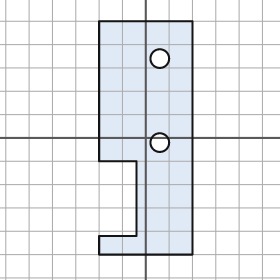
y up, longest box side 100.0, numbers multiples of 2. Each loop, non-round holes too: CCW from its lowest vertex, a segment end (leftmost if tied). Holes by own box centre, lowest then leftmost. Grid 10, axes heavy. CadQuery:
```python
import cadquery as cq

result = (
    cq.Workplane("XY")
    .moveTo(-20.0, -50.0)
    .lineTo(20.0, -50.0)
    .lineTo(20.0, 50.0)
    .lineTo(-20.0, 50.0)
    .lineTo(-20.0, -10.0)
    .lineTo(-4.0, -10.0)
    .lineTo(-4.0, -42.0)
    .lineTo(-20.0, -42.0)
    .close()
    .moveTo(6.0, -2.0)
    .circle(4.0)
    .moveTo(6.0, 34.0)
    .circle(4.0)
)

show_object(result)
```